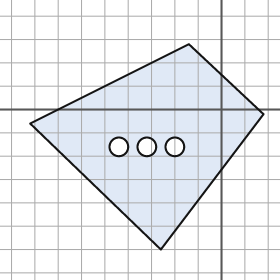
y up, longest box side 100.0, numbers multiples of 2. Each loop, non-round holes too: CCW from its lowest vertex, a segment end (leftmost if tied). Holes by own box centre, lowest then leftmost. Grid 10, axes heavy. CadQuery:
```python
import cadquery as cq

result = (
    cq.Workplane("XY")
    .moveTo(-26.0, -60.0)
    .lineTo(18.0, -2.0)
    .lineTo(-14.0, 28.0)
    .lineTo(-82.0, -6.0)
    .close()
    .moveTo(-44.0, -16.0)
    .circle(4.0)
    .moveTo(-32.0, -16.0)
    .circle(4.0)
    .moveTo(-20.0, -16.0)
    .circle(4.0)
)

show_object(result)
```